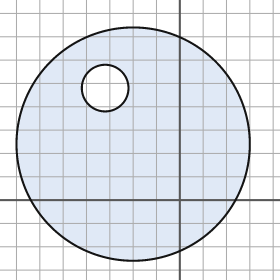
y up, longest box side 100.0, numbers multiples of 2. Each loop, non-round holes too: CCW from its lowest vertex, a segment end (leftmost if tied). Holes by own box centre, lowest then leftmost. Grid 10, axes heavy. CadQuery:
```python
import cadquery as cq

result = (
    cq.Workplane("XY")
    .moveTo(-20.0, 24.0)
    .circle(50.0)
    .moveTo(-32.0, 48.0)
    .circle(10.0)
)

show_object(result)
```